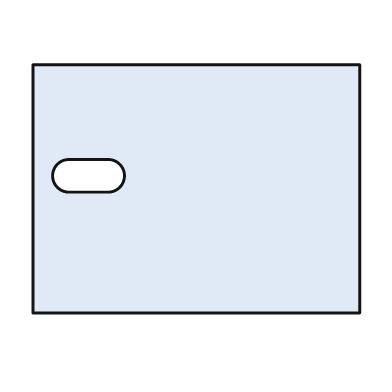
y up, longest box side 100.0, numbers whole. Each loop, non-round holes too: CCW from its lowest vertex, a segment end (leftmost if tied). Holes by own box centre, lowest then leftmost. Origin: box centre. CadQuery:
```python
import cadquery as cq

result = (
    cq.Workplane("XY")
    .moveTo(-50.0, -38.0)
    .lineTo(50.0, -38.0)
    .lineTo(50.0, 38.0)
    .lineTo(-50.0, 38.0)
    .close()
    .moveTo(-39.0, -1.0)
    .lineTo(-27.0, -1.0)
    .threePointArc((-22.0, 4.0), (-27.0, 9.0))
    .lineTo(-39.0, 9.0)
    .threePointArc((-44.0, 4.0), (-39.0, -1.0))
    .close()
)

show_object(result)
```